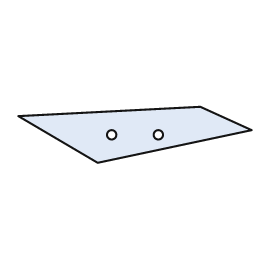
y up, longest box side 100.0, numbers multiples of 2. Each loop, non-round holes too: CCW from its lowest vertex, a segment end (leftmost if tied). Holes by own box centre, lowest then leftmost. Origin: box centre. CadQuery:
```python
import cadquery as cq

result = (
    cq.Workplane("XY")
    .moveTo(-16.0, -12.0)
    .lineTo(50.0, 2.0)
    .lineTo(28.0, 12.0)
    .lineTo(-50.0, 8.0)
    .close()
    .moveTo(-10.0, 0.0)
    .circle(2.0)
    .moveTo(10.0, 0.0)
    .circle(2.0)
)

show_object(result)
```